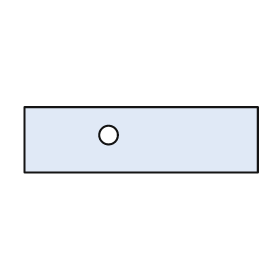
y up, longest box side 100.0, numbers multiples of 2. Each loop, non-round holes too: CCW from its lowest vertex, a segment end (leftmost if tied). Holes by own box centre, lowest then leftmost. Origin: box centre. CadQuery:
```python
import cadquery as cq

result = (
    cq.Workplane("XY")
    .moveTo(-50.0, -14.0)
    .lineTo(50.0, -14.0)
    .lineTo(50.0, 14.0)
    .lineTo(-50.0, 14.0)
    .close()
    .moveTo(-14.0, 2.0)
    .circle(4.0)
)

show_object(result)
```